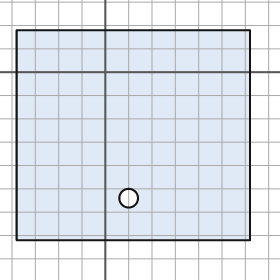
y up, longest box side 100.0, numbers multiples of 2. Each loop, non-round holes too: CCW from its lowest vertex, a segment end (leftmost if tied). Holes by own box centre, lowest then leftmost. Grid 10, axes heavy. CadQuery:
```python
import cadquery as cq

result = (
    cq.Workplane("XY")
    .moveTo(-38.0, -72.0)
    .lineTo(62.0, -72.0)
    .lineTo(62.0, 18.0)
    .lineTo(-38.0, 18.0)
    .close()
    .moveTo(10.0, -54.0)
    .circle(4.0)
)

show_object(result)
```